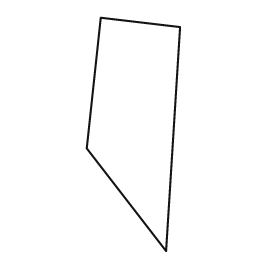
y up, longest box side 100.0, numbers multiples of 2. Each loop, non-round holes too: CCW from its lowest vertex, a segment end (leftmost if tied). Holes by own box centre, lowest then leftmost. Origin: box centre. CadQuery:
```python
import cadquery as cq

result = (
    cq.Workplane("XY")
    .moveTo(14.0, -50.0)
    .lineTo(20.0, 46.0)
    .lineTo(-14.0, 50.0)
    .lineTo(-20.0, -6.0)
    .close()
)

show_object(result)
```